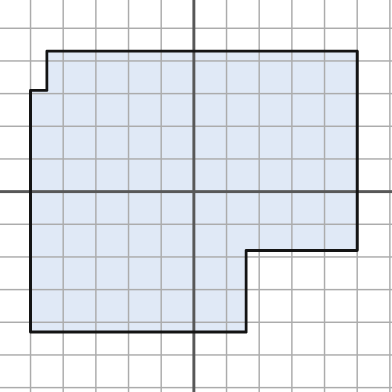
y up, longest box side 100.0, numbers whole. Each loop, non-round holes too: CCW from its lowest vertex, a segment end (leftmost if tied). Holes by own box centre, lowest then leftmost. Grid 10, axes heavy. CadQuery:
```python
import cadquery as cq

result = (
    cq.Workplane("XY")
    .moveTo(-50.0, -43.0)
    .lineTo(16.0, -43.0)
    .lineTo(16.0, -18.0)
    .lineTo(50.0, -18.0)
    .lineTo(50.0, 43.0)
    .lineTo(-45.0, 43.0)
    .lineTo(-45.0, 31.0)
    .lineTo(-50.0, 31.0)
    .close()
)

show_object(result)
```